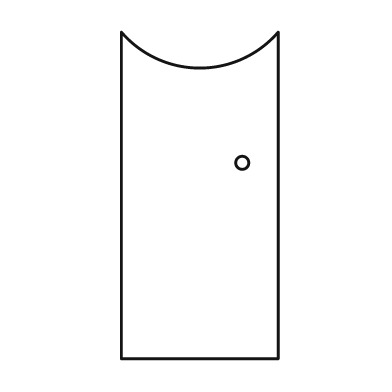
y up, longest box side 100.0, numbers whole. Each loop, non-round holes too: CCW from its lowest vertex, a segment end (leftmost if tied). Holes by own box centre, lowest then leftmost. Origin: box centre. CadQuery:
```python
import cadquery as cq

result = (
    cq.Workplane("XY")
    .moveTo(-24.0, -50.0)
    .lineTo(24.0, -50.0)
    .lineTo(24.0, 50.0)
    .threePointArc((0.0, 39.0), (-24.0, 50.0))
    .close()
    .moveTo(13.0, 10.0)
    .circle(2.0)
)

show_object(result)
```